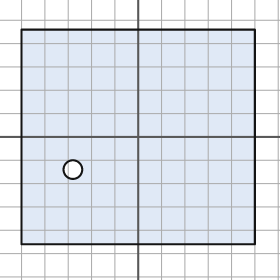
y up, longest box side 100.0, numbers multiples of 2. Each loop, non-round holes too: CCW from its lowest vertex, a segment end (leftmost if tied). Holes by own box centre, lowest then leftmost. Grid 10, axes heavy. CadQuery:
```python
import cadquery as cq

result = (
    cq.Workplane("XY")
    .moveTo(-50.0, -46.0)
    .lineTo(50.0, -46.0)
    .lineTo(50.0, 46.0)
    .lineTo(-50.0, 46.0)
    .close()
    .moveTo(-28.0, -14.0)
    .circle(4.0)
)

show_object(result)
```